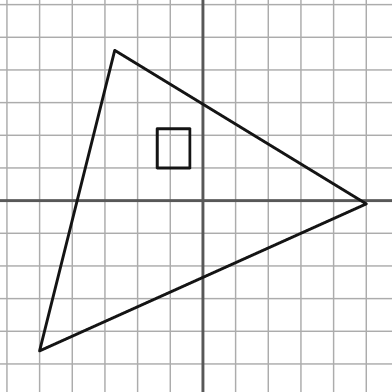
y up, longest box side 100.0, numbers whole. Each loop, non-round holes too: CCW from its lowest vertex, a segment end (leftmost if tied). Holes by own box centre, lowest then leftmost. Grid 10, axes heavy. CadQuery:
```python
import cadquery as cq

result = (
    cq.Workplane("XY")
    .moveTo(-50.0, -46.0)
    .lineTo(50.0, -1.0)
    .lineTo(-27.0, 46.0)
    .close()
    .moveTo(-14.0, 10.0)
    .lineTo(-4.0, 10.0)
    .lineTo(-4.0, 22.0)
    .lineTo(-14.0, 22.0)
    .close()
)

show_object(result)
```